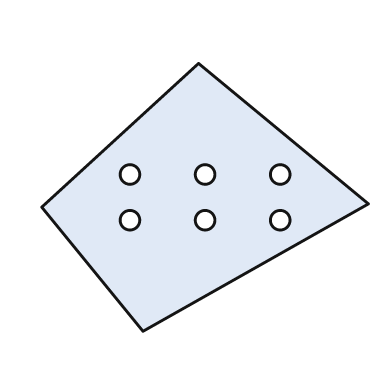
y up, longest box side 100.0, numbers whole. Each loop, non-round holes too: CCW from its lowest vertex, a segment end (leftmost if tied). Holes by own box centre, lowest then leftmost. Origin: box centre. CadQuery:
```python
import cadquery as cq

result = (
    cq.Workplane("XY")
    .moveTo(-19.0, -41.0)
    .lineTo(50.0, -2.0)
    .lineTo(-2.0, 41.0)
    .lineTo(-50.0, -3.0)
    .close()
    .moveTo(-23.0, -7.0)
    .circle(3.0)
    .moveTo(0.0, -7.0)
    .circle(3.0)
    .moveTo(23.0, -7.0)
    .circle(3.0)
    .moveTo(-23.0, 7.0)
    .circle(3.0)
    .moveTo(0.0, 7.0)
    .circle(3.0)
    .moveTo(23.0, 7.0)
    .circle(3.0)
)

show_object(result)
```